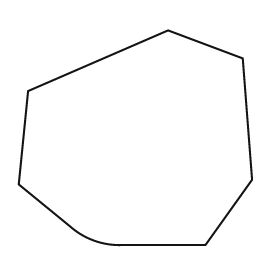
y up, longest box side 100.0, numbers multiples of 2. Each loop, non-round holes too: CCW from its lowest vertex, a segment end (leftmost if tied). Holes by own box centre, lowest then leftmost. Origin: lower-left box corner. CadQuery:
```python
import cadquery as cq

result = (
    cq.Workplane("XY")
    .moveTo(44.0, 0.0)
    .lineTo(80.0, 0.0)
    .lineTo(100.0, 28.0)
    .lineTo(96.0, 80.0)
    .lineTo(64.0, 92.0)
    .lineTo(4.0, 66.0)
    .lineTo(0.0, 26.0)
    .lineTo(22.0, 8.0)
    .threePointArc((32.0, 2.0), (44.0, 0.0))
    .close()
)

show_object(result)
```